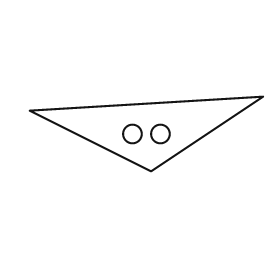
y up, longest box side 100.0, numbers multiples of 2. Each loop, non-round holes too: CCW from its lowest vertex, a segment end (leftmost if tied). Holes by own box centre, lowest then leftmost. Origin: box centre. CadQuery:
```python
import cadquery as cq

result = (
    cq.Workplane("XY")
    .moveTo(2.0, -16.0)
    .lineTo(50.0, 16.0)
    .lineTo(-50.0, 10.0)
    .close()
    .moveTo(-6.0, 0.0)
    .circle(4.0)
    .moveTo(6.0, 0.0)
    .circle(4.0)
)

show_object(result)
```